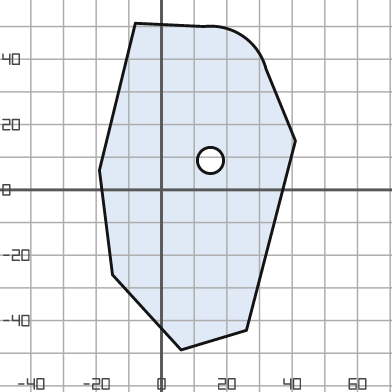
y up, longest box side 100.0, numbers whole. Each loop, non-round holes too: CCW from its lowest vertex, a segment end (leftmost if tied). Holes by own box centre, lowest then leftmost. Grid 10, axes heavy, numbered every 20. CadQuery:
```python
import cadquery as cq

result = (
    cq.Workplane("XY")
    .moveTo(6.0, -49.0)
    .lineTo(26.0, -43.0)
    .lineTo(41.0, 15.0)
    .lineTo(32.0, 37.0)
    .threePointArc((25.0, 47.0), (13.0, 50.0))
    .lineTo(-8.0, 51.0)
    .lineTo(-19.0, 6.0)
    .lineTo(-15.0, -26.0)
    .close()
    .moveTo(15.0, 9.0)
    .circle(4.0)
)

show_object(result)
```